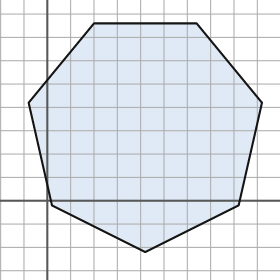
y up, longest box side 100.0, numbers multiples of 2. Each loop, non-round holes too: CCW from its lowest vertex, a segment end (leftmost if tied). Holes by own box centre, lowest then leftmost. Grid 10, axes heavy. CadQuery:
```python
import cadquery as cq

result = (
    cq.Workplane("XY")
    .moveTo(42.0, -22.0)
    .lineTo(82.0, -2.0)
    .lineTo(92.0, 42.0)
    .lineTo(64.0, 76.0)
    .lineTo(20.0, 76.0)
    .lineTo(-8.0, 42.0)
    .lineTo(2.0, -2.0)
    .close()
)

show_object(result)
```